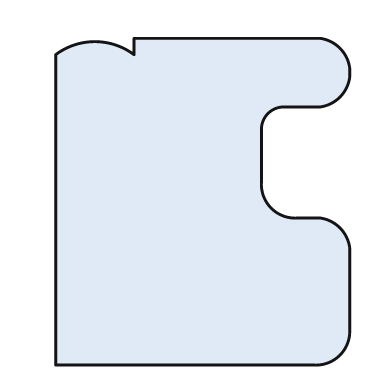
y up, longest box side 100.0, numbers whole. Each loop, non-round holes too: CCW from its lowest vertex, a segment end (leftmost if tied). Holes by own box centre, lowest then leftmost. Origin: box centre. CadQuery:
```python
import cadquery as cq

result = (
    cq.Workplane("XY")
    .moveTo(-45.0, -50.0)
    .lineTo(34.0, -50.0)
    .threePointArc((42.0, -47.0), (45.0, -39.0))
    .lineTo(45.0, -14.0)
    .threePointArc((42.0, -8.0), (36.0, -5.0))
    .lineTo(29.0, -5.0)
    .threePointArc((21.0, -2.0), (18.0, 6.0))
    .lineTo(18.0, 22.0)
    .threePointArc((20.0, 27.0), (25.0, 29.0))
    .lineTo(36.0, 29.0)
    .threePointArc((42.0, 32.0), (45.0, 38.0))
    .lineTo(45.0, 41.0)
    .threePointArc((42.0, 47.0), (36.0, 50.0))
    .lineTo(-21.0, 50.0)
    .lineTo(-21.0, 45.0)
    .threePointArc((-33.0, 49.0), (-45.0, 45.0))
    .close()
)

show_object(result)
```